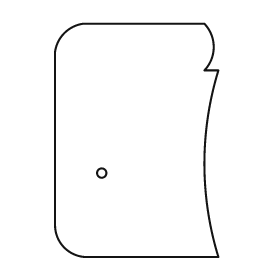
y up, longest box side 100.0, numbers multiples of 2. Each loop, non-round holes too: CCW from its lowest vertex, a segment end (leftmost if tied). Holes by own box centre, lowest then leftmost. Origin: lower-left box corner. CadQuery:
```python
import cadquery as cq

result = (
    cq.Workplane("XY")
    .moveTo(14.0, 0.0)
    .lineTo(70.0, 0.0)
    .threePointArc((64.0, 40.0), (70.0, 80.0))
    .lineTo(64.0, 80.0)
    .threePointArc((68.0, 90.0), (64.0, 100.0))
    .lineTo(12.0, 100.0)
    .threePointArc((4.0, 96.0), (0.0, 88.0))
    .lineTo(0.0, 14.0)
    .threePointArc((4.0, 4.0), (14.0, 0.0))
    .close()
    .moveTo(20.0, 36.0)
    .circle(2.0)
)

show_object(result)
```